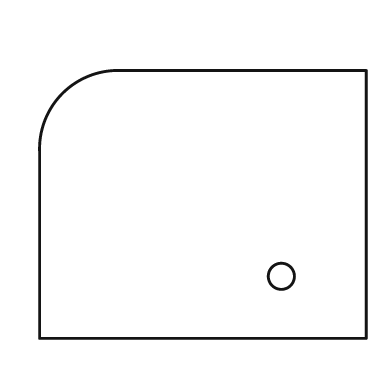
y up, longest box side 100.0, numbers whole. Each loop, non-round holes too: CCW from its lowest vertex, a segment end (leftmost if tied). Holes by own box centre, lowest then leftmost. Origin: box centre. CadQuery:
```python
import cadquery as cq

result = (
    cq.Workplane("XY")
    .moveTo(-50.0, -41.0)
    .lineTo(50.0, -41.0)
    .lineTo(50.0, 41.0)
    .lineTo(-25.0, 41.0)
    .threePointArc((-43.0, 34.0), (-50.0, 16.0))
    .close()
    .moveTo(24.0, -22.0)
    .circle(4.0)
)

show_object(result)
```